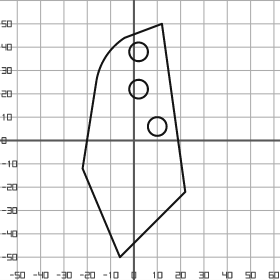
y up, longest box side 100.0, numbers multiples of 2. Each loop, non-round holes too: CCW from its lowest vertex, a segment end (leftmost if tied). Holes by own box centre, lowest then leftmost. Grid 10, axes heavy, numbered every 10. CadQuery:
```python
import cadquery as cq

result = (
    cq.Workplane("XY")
    .moveTo(-6.0, -50.0)
    .lineTo(22.0, -22.0)
    .lineTo(12.0, 50.0)
    .lineTo(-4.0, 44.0)
    .threePointArc((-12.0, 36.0), (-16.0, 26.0))
    .lineTo(-22.0, -12.0)
    .close()
    .moveTo(10.0, 6.0)
    .circle(4.0)
    .moveTo(2.0, 22.0)
    .circle(4.0)
    .moveTo(2.0, 38.0)
    .circle(4.0)
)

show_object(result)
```